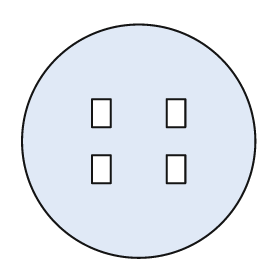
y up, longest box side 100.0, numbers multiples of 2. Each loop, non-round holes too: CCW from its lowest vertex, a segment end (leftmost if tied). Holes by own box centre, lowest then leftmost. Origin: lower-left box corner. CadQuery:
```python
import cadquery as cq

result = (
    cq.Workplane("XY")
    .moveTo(50.0, 50.0)
    .circle(50.0)
    .moveTo(30.0, 32.0)
    .lineTo(38.0, 32.0)
    .lineTo(38.0, 44.0)
    .lineTo(30.0, 44.0)
    .close()
    .moveTo(62.0, 32.0)
    .lineTo(70.0, 32.0)
    .lineTo(70.0, 44.0)
    .lineTo(62.0, 44.0)
    .close()
    .moveTo(30.0, 56.0)
    .lineTo(38.0, 56.0)
    .lineTo(38.0, 68.0)
    .lineTo(30.0, 68.0)
    .close()
    .moveTo(62.0, 56.0)
    .lineTo(70.0, 56.0)
    .lineTo(70.0, 68.0)
    .lineTo(62.0, 68.0)
    .close()
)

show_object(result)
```